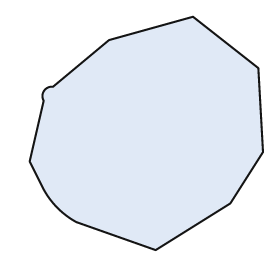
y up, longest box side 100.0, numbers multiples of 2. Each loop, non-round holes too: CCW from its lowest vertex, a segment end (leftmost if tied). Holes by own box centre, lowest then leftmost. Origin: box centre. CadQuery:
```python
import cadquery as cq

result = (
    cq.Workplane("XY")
    .moveTo(4.0, -50.0)
    .lineTo(36.0, -30.0)
    .lineTo(50.0, -8.0)
    .lineTo(48.0, 28.0)
    .lineTo(20.0, 50.0)
    .lineTo(-16.0, 40.0)
    .lineTo(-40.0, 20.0)
    .threePointArc((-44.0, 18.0), (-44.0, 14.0))
    .lineTo(-50.0, -12.0)
    .lineTo(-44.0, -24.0)
    .threePointArc((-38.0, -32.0), (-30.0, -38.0))
    .close()
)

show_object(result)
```